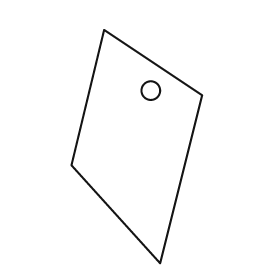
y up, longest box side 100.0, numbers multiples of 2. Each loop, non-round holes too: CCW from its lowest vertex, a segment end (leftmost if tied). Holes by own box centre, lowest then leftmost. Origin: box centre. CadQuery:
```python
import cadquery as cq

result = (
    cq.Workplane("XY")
    .moveTo(10.0, -50.0)
    .lineTo(28.0, 22.0)
    .lineTo(-14.0, 50.0)
    .lineTo(-28.0, -8.0)
    .close()
    .moveTo(6.0, 24.0)
    .circle(4.0)
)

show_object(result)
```